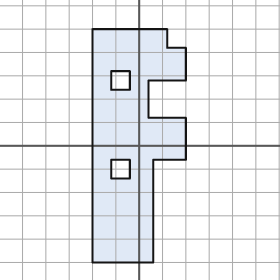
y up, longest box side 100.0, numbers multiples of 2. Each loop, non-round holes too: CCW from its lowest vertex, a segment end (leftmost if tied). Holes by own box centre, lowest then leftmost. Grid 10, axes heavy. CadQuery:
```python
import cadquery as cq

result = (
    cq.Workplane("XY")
    .moveTo(-20.0, -50.0)
    .lineTo(6.0, -50.0)
    .lineTo(6.0, -6.0)
    .lineTo(20.0, -6.0)
    .lineTo(20.0, 12.0)
    .lineTo(4.0, 12.0)
    .lineTo(4.0, 28.0)
    .lineTo(20.0, 28.0)
    .lineTo(20.0, 42.0)
    .lineTo(12.0, 42.0)
    .lineTo(12.0, 50.0)
    .lineTo(-20.0, 50.0)
    .close()
    .moveTo(-12.0, -14.0)
    .lineTo(-4.0, -14.0)
    .lineTo(-4.0, -6.0)
    .lineTo(-12.0, -6.0)
    .close()
    .moveTo(-12.0, 24.0)
    .lineTo(-4.0, 24.0)
    .lineTo(-4.0, 32.0)
    .lineTo(-12.0, 32.0)
    .close()
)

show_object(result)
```